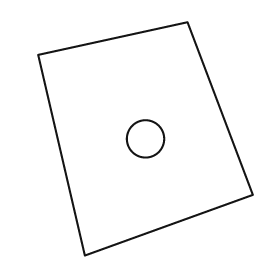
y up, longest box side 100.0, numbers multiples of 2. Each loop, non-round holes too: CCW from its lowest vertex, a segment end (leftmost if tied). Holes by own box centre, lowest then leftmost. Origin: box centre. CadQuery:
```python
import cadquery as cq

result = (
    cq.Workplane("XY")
    .moveTo(-26.0, -50.0)
    .lineTo(46.0, -24.0)
    .lineTo(18.0, 50.0)
    .lineTo(-46.0, 36.0)
    .close()
    .moveTo(0.0, 0.0)
    .circle(8.0)
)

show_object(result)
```